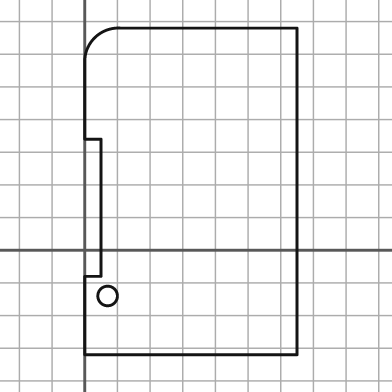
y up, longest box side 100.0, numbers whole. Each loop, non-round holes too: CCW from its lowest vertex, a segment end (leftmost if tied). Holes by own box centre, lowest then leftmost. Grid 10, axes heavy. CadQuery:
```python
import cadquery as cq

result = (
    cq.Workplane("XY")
    .moveTo(0.0, -32.0)
    .lineTo(65.0, -32.0)
    .lineTo(65.0, 68.0)
    .lineTo(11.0, 68.0)
    .threePointArc((3.0, 65.0), (0.0, 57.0))
    .lineTo(0.0, 34.0)
    .lineTo(5.0, 34.0)
    .lineTo(5.0, -8.0)
    .lineTo(0.0, -8.0)
    .close()
    .moveTo(7.0, -14.0)
    .circle(3.0)
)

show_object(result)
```